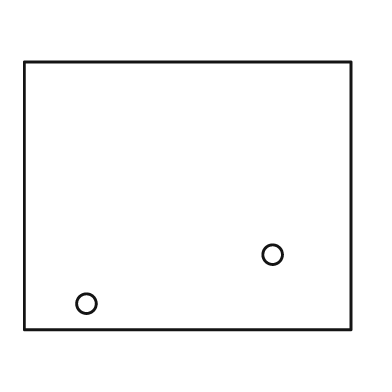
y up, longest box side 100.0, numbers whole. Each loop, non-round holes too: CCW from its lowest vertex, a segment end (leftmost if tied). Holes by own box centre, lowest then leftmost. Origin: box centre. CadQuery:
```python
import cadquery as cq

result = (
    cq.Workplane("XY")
    .moveTo(-50.0, -41.0)
    .lineTo(50.0, -41.0)
    .lineTo(50.0, 41.0)
    .lineTo(-50.0, 41.0)
    .close()
    .moveTo(-31.0, -33.0)
    .circle(3.0)
    .moveTo(26.0, -18.0)
    .circle(3.0)
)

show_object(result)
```